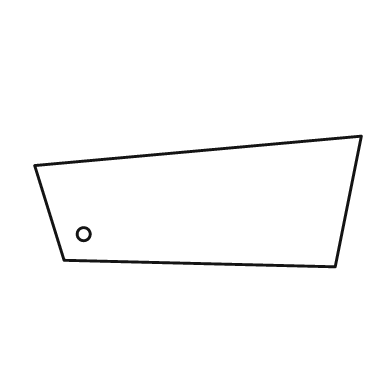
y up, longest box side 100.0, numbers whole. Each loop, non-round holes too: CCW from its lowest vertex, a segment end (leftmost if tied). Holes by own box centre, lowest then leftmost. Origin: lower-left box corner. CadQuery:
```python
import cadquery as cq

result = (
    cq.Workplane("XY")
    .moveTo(92.0, 0.0)
    .lineTo(100.0, 40.0)
    .lineTo(0.0, 31.0)
    .lineTo(9.0, 2.0)
    .close()
    .moveTo(15.0, 10.0)
    .circle(2.0)
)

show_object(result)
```